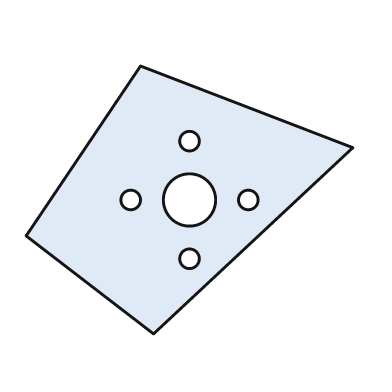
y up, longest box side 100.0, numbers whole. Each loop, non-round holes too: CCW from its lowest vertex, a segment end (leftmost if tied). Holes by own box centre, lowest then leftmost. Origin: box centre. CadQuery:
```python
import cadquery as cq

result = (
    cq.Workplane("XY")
    .moveTo(-11.0, -41.0)
    .lineTo(50.0, 16.0)
    .lineTo(-15.0, 41.0)
    .lineTo(-50.0, -11.0)
    .close()
    .moveTo(0.0, -18.0)
    .circle(3.0)
    .moveTo(-18.0, 0.0)
    .circle(3.0)
    .moveTo(0.0, 0.0)
    .circle(8.0)
    .moveTo(18.0, 0.0)
    .circle(3.0)
    .moveTo(0.0, 18.0)
    .circle(3.0)
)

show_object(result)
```